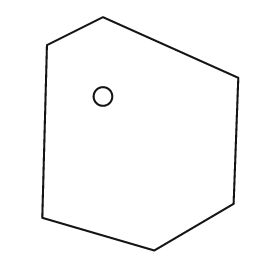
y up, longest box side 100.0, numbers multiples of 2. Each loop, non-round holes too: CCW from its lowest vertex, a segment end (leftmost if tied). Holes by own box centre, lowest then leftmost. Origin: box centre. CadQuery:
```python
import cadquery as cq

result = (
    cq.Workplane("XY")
    .moveTo(6.0, -50.0)
    .lineTo(40.0, -30.0)
    .lineTo(42.0, 24.0)
    .lineTo(-16.0, 50.0)
    .lineTo(-40.0, 38.0)
    .lineTo(-42.0, -36.0)
    .close()
    .moveTo(-16.0, 16.0)
    .circle(4.0)
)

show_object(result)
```